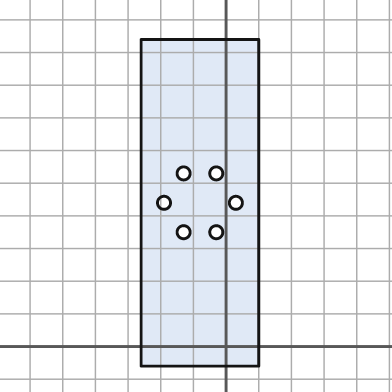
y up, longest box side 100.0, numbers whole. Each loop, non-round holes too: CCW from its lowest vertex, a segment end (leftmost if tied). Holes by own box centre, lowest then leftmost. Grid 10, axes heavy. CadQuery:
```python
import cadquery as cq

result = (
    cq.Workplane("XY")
    .moveTo(-26.0, -6.0)
    .lineTo(10.0, -6.0)
    .lineTo(10.0, 94.0)
    .lineTo(-26.0, 94.0)
    .close()
    .moveTo(-13.0, 35.0)
    .circle(2.0)
    .moveTo(-3.0, 35.0)
    .circle(2.0)
    .moveTo(-19.0, 44.0)
    .circle(2.0)
    .moveTo(3.0, 44.0)
    .circle(2.0)
    .moveTo(-13.0, 53.0)
    .circle(2.0)
    .moveTo(-3.0, 53.0)
    .circle(2.0)
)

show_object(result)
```